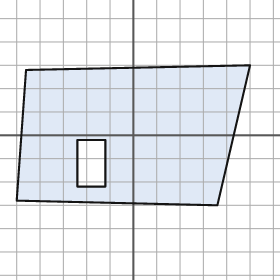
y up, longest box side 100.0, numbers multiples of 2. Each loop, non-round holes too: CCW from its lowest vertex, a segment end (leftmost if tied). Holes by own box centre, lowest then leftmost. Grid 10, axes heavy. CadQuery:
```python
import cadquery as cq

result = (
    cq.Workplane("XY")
    .moveTo(36.0, -30.0)
    .lineTo(50.0, 30.0)
    .lineTo(-46.0, 28.0)
    .lineTo(-50.0, -28.0)
    .close()
    .moveTo(-24.0, -22.0)
    .lineTo(-12.0, -22.0)
    .lineTo(-12.0, -2.0)
    .lineTo(-24.0, -2.0)
    .close()
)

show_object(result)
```